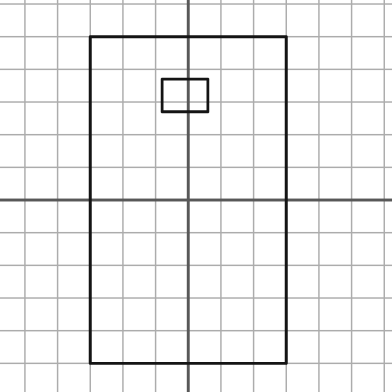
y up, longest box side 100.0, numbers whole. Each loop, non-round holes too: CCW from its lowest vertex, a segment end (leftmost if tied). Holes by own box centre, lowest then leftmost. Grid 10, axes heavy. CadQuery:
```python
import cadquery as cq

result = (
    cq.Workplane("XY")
    .moveTo(-30.0, -50.0)
    .lineTo(30.0, -50.0)
    .lineTo(30.0, 50.0)
    .lineTo(-30.0, 50.0)
    .close()
    .moveTo(-8.0, 27.0)
    .lineTo(6.0, 27.0)
    .lineTo(6.0, 37.0)
    .lineTo(-8.0, 37.0)
    .close()
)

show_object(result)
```